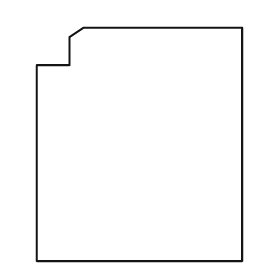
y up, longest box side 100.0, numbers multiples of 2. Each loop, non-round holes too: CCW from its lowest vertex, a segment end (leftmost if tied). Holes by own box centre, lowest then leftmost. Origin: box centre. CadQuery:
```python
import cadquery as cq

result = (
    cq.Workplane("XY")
    .moveTo(-44.0, -50.0)
    .lineTo(44.0, -50.0)
    .lineTo(44.0, 50.0)
    .lineTo(-24.0, 50.0)
    .lineTo(-30.0, 46.0)
    .lineTo(-30.0, 34.0)
    .lineTo(-44.0, 34.0)
    .close()
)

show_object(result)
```